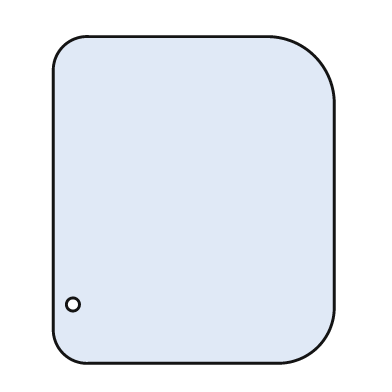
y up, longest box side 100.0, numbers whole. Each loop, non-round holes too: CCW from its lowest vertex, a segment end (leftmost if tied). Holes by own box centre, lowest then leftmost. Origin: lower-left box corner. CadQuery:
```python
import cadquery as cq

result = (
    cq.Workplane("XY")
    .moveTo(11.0, 0.0)
    .lineTo(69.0, 0.0)
    .threePointArc((81.0, 5.0), (86.0, 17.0))
    .lineTo(86.0, 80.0)
    .threePointArc((80.0, 94.0), (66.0, 100.0))
    .lineTo(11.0, 100.0)
    .threePointArc((3.0, 97.0), (0.0, 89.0))
    .lineTo(0.0, 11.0)
    .threePointArc((3.0, 3.0), (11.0, 0.0))
    .close()
    .moveTo(6.0, 18.0)
    .circle(2.0)
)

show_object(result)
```